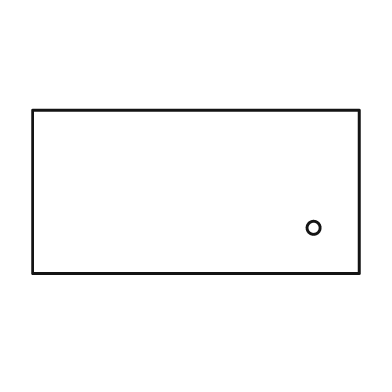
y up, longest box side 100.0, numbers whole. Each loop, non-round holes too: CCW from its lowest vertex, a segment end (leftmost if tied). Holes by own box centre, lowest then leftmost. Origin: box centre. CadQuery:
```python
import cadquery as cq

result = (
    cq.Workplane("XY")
    .moveTo(-50.0, -25.0)
    .lineTo(50.0, -25.0)
    .lineTo(50.0, 25.0)
    .lineTo(-50.0, 25.0)
    .close()
    .moveTo(36.0, -11.0)
    .circle(2.0)
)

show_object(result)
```